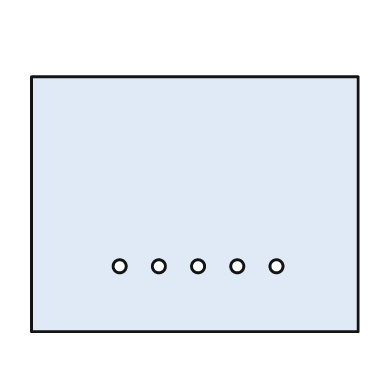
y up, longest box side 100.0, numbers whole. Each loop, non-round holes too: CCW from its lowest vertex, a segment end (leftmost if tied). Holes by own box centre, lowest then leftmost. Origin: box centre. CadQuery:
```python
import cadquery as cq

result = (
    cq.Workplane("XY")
    .moveTo(-50.0, -39.0)
    .lineTo(50.0, -39.0)
    .lineTo(50.0, 39.0)
    .lineTo(-50.0, 39.0)
    .close()
    .moveTo(-23.0, -19.0)
    .circle(2.0)
    .moveTo(-11.0, -19.0)
    .circle(2.0)
    .moveTo(1.0, -19.0)
    .circle(2.0)
    .moveTo(13.0, -19.0)
    .circle(2.0)
    .moveTo(25.0, -19.0)
    .circle(2.0)
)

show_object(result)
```